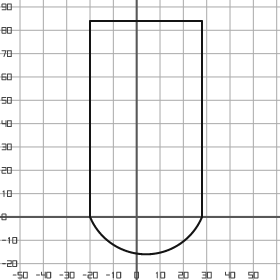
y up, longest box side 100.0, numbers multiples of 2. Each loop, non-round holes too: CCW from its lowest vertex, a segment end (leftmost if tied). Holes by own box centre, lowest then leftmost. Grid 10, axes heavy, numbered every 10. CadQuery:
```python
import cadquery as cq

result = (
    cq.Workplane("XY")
    .moveTo(-20.0, 0.0)
    .threePointArc((4.0, -16.0), (28.0, 0.0))
    .lineTo(28.0, 84.0)
    .lineTo(-20.0, 84.0)
    .close()
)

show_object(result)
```